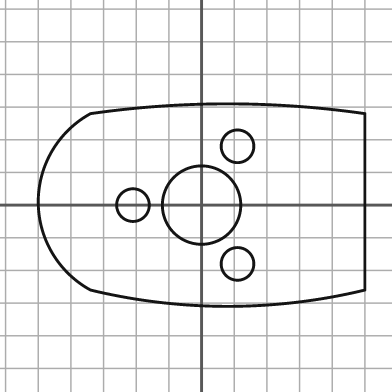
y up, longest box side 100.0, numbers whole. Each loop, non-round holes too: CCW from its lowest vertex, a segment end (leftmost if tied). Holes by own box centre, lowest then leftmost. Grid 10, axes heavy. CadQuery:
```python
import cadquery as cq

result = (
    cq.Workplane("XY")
    .moveTo(-34.0, -26.0)
    .threePointArc((8.0, -31.0), (50.0, -26.0))
    .lineTo(50.0, 28.0)
    .threePointArc((8.0, 31.0), (-34.0, 28.0))
    .threePointArc((-50.0, 1.0), (-34.0, -26.0))
    .close()
    .moveTo(11.0, -18.0)
    .circle(5.0)
    .moveTo(-21.0, 0.0)
    .circle(5.0)
    .moveTo(0.0, 0.0)
    .circle(12.0)
    .moveTo(11.0, 18.0)
    .circle(5.0)
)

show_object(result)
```